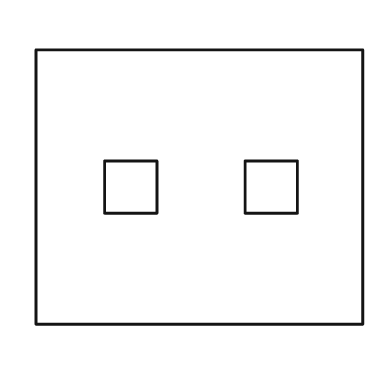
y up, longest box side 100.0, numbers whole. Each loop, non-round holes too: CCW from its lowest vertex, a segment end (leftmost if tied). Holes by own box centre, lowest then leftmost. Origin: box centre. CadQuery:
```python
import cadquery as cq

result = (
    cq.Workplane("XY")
    .moveTo(-50.0, -42.0)
    .lineTo(50.0, -42.0)
    .lineTo(50.0, 42.0)
    .lineTo(-50.0, 42.0)
    .close()
    .moveTo(-29.0, -8.0)
    .lineTo(-13.0, -8.0)
    .lineTo(-13.0, 8.0)
    .lineTo(-29.0, 8.0)
    .close()
    .moveTo(14.0, -8.0)
    .lineTo(30.0, -8.0)
    .lineTo(30.0, 8.0)
    .lineTo(14.0, 8.0)
    .close()
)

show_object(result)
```